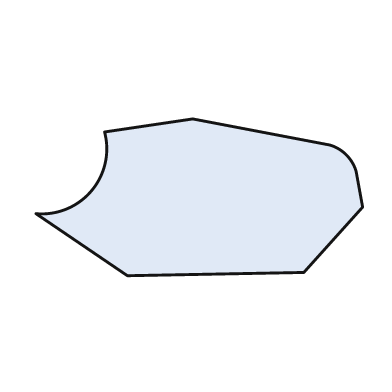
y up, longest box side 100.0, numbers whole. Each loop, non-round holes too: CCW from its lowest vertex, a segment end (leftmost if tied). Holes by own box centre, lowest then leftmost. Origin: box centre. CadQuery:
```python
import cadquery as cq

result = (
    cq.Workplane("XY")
    .moveTo(-22.0, -24.0)
    .lineTo(32.0, -23.0)
    .lineTo(50.0, -3.0)
    .lineTo(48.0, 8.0)
    .threePointArc((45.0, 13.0), (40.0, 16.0))
    .lineTo(-2.0, 24.0)
    .lineTo(-29.0, 20.0)
    .threePointArc((-33.0, 2.0), (-50.0, -5.0))
    .close()
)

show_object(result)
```